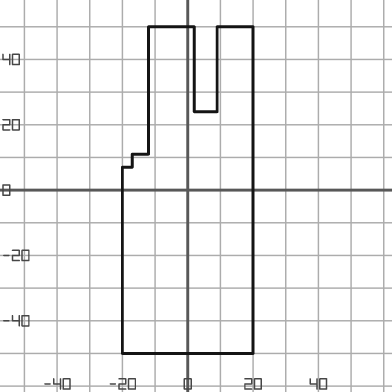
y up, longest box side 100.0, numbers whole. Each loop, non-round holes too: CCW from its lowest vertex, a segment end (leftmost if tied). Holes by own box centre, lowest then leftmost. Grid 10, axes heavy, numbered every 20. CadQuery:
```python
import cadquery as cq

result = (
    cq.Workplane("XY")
    .moveTo(-20.0, -50.0)
    .lineTo(20.0, -50.0)
    .lineTo(20.0, 50.0)
    .lineTo(9.0, 50.0)
    .lineTo(9.0, 24.0)
    .lineTo(2.0, 24.0)
    .lineTo(2.0, 50.0)
    .lineTo(-12.0, 50.0)
    .lineTo(-12.0, 11.0)
    .lineTo(-17.0, 11.0)
    .lineTo(-17.0, 7.0)
    .lineTo(-20.0, 7.0)
    .close()
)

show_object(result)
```